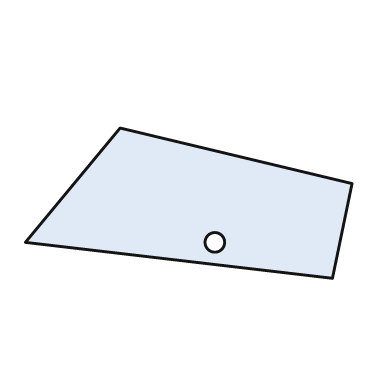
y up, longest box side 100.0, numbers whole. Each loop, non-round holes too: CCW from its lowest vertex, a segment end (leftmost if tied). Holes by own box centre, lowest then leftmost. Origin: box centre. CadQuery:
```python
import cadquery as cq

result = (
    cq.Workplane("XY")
    .moveTo(44.0, -23.0)
    .lineTo(50.0, 6.0)
    .lineTo(-21.0, 23.0)
    .lineTo(-50.0, -12.0)
    .close()
    .moveTo(8.0, -12.0)
    .circle(3.0)
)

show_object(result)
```